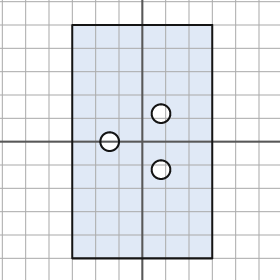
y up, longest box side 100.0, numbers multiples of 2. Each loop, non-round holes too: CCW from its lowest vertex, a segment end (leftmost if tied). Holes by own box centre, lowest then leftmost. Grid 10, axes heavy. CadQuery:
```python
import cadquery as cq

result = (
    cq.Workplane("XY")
    .moveTo(-30.0, -50.0)
    .lineTo(30.0, -50.0)
    .lineTo(30.0, 50.0)
    .lineTo(-30.0, 50.0)
    .close()
    .moveTo(8.0, -12.0)
    .circle(4.0)
    .moveTo(-14.0, 0.0)
    .circle(4.0)
    .moveTo(8.0, 12.0)
    .circle(4.0)
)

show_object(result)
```